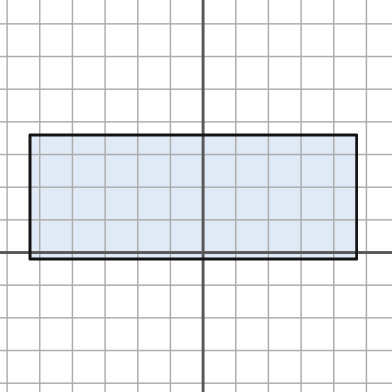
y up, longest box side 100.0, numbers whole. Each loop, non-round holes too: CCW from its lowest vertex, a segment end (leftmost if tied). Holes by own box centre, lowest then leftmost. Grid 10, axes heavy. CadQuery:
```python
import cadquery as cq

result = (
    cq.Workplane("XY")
    .moveTo(-53.0, -2.0)
    .lineTo(47.0, -2.0)
    .lineTo(47.0, 36.0)
    .lineTo(-53.0, 36.0)
    .close()
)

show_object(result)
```